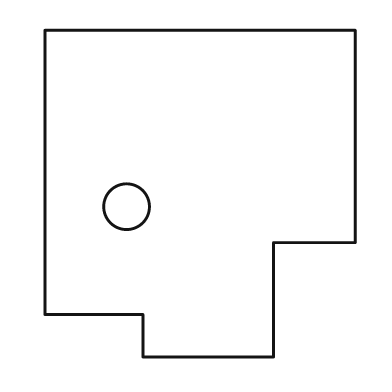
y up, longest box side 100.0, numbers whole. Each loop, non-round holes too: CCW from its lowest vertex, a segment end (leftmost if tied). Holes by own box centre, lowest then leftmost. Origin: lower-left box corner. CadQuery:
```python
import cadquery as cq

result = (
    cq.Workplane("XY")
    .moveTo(30.0, 0.0)
    .lineTo(70.0, 0.0)
    .lineTo(70.0, 35.0)
    .lineTo(95.0, 35.0)
    .lineTo(95.0, 100.0)
    .lineTo(0.0, 100.0)
    .lineTo(0.0, 13.0)
    .lineTo(30.0, 13.0)
    .close()
    .moveTo(25.0, 46.0)
    .circle(7.0)
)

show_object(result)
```